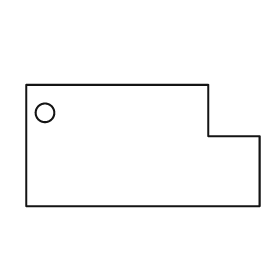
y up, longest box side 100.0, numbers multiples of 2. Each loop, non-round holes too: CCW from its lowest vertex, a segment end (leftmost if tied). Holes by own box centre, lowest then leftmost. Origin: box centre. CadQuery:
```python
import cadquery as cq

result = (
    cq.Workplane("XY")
    .moveTo(-50.0, -26.0)
    .lineTo(50.0, -26.0)
    .lineTo(50.0, 4.0)
    .lineTo(28.0, 4.0)
    .lineTo(28.0, 26.0)
    .lineTo(-50.0, 26.0)
    .close()
    .moveTo(-42.0, 14.0)
    .circle(4.0)
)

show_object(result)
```